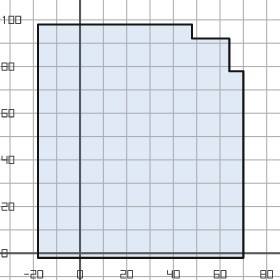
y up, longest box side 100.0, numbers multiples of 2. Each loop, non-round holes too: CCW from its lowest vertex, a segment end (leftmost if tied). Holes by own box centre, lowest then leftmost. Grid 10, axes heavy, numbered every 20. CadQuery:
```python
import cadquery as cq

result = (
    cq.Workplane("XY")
    .moveTo(-18.0, -2.0)
    .lineTo(70.0, -2.0)
    .lineTo(70.0, 78.0)
    .lineTo(64.0, 78.0)
    .lineTo(64.0, 92.0)
    .lineTo(48.0, 92.0)
    .lineTo(48.0, 98.0)
    .lineTo(-18.0, 98.0)
    .close()
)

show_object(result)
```